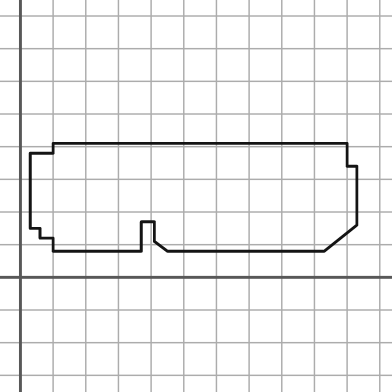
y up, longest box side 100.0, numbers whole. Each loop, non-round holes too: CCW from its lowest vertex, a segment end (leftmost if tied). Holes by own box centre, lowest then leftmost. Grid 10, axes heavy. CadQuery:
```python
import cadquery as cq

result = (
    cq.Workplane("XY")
    .moveTo(10.0, 8.0)
    .lineTo(37.0, 8.0)
    .lineTo(37.0, 17.0)
    .lineTo(41.0, 17.0)
    .lineTo(41.0, 11.0)
    .lineTo(45.0, 8.0)
    .lineTo(93.0, 8.0)
    .lineTo(103.0, 16.0)
    .lineTo(103.0, 34.0)
    .lineTo(100.0, 34.0)
    .lineTo(100.0, 41.0)
    .lineTo(10.0, 41.0)
    .lineTo(10.0, 38.0)
    .lineTo(3.0, 38.0)
    .lineTo(3.0, 15.0)
    .lineTo(6.0, 15.0)
    .lineTo(6.0, 12.0)
    .lineTo(10.0, 12.0)
    .close()
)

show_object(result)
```